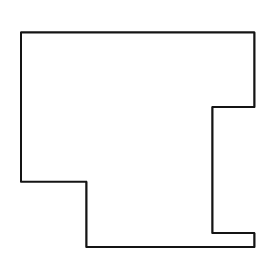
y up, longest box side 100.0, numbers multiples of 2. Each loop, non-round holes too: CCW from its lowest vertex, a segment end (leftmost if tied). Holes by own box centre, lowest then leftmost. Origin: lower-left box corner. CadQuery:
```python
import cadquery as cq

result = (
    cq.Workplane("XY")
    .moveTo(28.0, 0.0)
    .lineTo(100.0, 0.0)
    .lineTo(100.0, 6.0)
    .lineTo(82.0, 6.0)
    .lineTo(82.0, 60.0)
    .lineTo(100.0, 60.0)
    .lineTo(100.0, 92.0)
    .lineTo(0.0, 92.0)
    .lineTo(0.0, 28.0)
    .lineTo(28.0, 28.0)
    .close()
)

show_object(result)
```